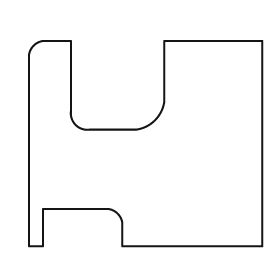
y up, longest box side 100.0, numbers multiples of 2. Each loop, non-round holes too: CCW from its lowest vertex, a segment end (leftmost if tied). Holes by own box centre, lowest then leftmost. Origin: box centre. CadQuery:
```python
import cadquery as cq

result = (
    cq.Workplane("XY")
    .moveTo(-50.0, -44.0)
    .lineTo(-44.0, -44.0)
    .lineTo(-44.0, -28.0)
    .lineTo(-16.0, -28.0)
    .threePointArc((-12.0, -30.0), (-10.0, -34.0))
    .lineTo(-10.0, -44.0)
    .lineTo(50.0, -44.0)
    .lineTo(50.0, 44.0)
    .lineTo(8.0, 44.0)
    .lineTo(8.0, 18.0)
    .threePointArc((4.0, 10.0), (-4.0, 6.0))
    .lineTo(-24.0, 6.0)
    .threePointArc((-30.0, 8.0), (-32.0, 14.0))
    .lineTo(-32.0, 44.0)
    .lineTo(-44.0, 44.0)
    .threePointArc((-48.0, 42.0), (-50.0, 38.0))
    .close()
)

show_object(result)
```